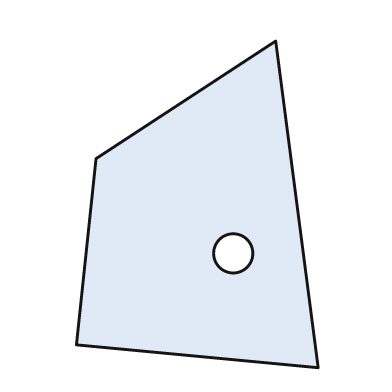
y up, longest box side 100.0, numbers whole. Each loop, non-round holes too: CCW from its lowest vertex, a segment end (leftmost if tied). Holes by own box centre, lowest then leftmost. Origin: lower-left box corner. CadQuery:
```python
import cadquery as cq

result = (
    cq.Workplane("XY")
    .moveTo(74.0, 0.0)
    .lineTo(61.0, 100.0)
    .lineTo(6.0, 64.0)
    .lineTo(0.0, 7.0)
    .close()
    .moveTo(48.0, 35.0)
    .circle(6.0)
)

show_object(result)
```